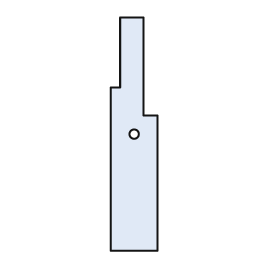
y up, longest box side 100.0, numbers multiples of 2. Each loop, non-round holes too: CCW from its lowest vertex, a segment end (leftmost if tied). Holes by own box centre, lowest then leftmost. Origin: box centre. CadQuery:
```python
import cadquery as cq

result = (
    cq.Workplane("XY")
    .moveTo(-10.0, -50.0)
    .lineTo(10.0, -50.0)
    .lineTo(10.0, 8.0)
    .lineTo(4.0, 8.0)
    .lineTo(4.0, 50.0)
    .lineTo(-6.0, 50.0)
    .lineTo(-6.0, 20.0)
    .lineTo(-10.0, 20.0)
    .close()
    .moveTo(0.0, 0.0)
    .circle(2.0)
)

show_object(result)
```